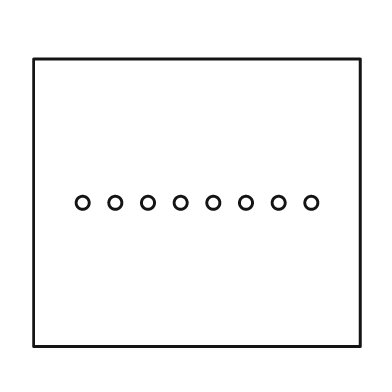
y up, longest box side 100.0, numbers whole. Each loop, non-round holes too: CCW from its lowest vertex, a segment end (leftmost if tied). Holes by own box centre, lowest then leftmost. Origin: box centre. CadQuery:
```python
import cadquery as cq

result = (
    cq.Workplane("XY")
    .moveTo(-50.0, -44.0)
    .lineTo(50.0, -44.0)
    .lineTo(50.0, 44.0)
    .lineTo(-50.0, 44.0)
    .close()
    .moveTo(-35.0, 0.0)
    .circle(2.0)
    .moveTo(-25.0, 0.0)
    .circle(2.0)
    .moveTo(-15.0, 0.0)
    .circle(2.0)
    .moveTo(-5.0, 0.0)
    .circle(2.0)
    .moveTo(5.0, 0.0)
    .circle(2.0)
    .moveTo(15.0, 0.0)
    .circle(2.0)
    .moveTo(25.0, 0.0)
    .circle(2.0)
    .moveTo(35.0, 0.0)
    .circle(2.0)
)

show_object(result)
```